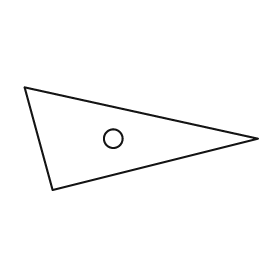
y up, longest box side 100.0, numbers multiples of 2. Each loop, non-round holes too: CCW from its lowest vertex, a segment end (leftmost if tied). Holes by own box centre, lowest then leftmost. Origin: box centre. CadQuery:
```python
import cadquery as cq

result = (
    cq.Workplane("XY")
    .moveTo(-38.0, -22.0)
    .lineTo(50.0, 0.0)
    .lineTo(-50.0, 22.0)
    .close()
    .moveTo(-12.0, 0.0)
    .circle(4.0)
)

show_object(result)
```